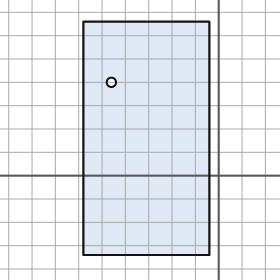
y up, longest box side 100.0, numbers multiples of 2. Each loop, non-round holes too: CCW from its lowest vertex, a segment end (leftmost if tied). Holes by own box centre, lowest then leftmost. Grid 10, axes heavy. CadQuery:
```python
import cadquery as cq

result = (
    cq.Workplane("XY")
    .moveTo(-58.0, -34.0)
    .lineTo(-4.0, -34.0)
    .lineTo(-4.0, 66.0)
    .lineTo(-58.0, 66.0)
    .close()
    .moveTo(-46.0, 40.0)
    .circle(2.0)
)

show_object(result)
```